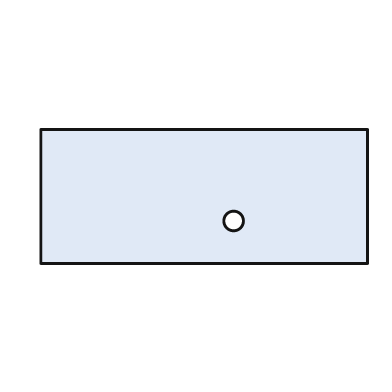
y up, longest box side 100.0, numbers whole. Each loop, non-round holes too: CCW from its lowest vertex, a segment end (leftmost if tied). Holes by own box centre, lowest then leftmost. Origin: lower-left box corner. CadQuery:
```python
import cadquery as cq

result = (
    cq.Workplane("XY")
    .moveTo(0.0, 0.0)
    .lineTo(100.0, 0.0)
    .lineTo(100.0, 41.0)
    .lineTo(0.0, 41.0)
    .close()
    .moveTo(59.0, 13.0)
    .circle(3.0)
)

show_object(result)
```